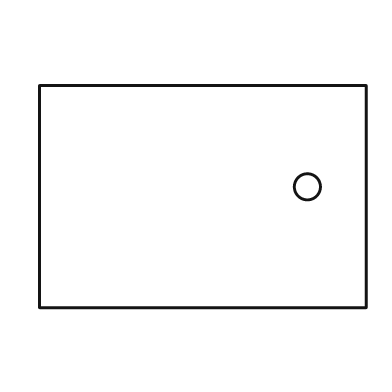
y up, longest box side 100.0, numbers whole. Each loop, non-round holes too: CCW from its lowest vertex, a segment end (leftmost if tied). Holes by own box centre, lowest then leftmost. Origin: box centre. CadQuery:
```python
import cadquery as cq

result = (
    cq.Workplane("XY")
    .moveTo(-50.0, -34.0)
    .lineTo(50.0, -34.0)
    .lineTo(50.0, 34.0)
    .lineTo(-50.0, 34.0)
    .close()
    .moveTo(32.0, 3.0)
    .circle(4.0)
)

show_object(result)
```